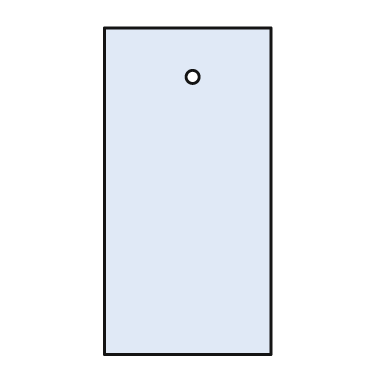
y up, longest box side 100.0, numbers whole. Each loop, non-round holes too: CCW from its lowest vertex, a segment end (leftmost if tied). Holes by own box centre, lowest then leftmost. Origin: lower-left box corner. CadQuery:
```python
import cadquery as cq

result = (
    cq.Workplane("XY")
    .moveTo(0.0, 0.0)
    .lineTo(51.0, 0.0)
    .lineTo(51.0, 100.0)
    .lineTo(0.0, 100.0)
    .close()
    .moveTo(27.0, 85.0)
    .circle(2.0)
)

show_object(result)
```